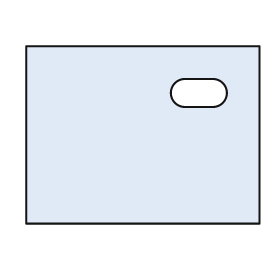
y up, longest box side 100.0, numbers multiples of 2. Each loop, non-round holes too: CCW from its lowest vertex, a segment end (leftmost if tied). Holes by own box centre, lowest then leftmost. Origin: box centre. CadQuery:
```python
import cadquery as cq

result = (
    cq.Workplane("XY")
    .moveTo(-50.0, -38.0)
    .lineTo(50.0, -38.0)
    .lineTo(50.0, 38.0)
    .lineTo(-50.0, 38.0)
    .close()
    .moveTo(18.0, 12.0)
    .lineTo(30.0, 12.0)
    .threePointArc((36.0, 18.0), (30.0, 24.0))
    .lineTo(18.0, 24.0)
    .threePointArc((12.0, 18.0), (18.0, 12.0))
    .close()
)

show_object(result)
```